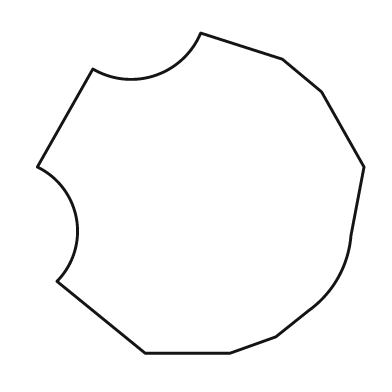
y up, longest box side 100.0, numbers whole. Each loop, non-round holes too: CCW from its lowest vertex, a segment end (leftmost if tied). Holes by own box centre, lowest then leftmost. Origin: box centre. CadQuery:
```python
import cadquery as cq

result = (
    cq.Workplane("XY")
    .moveTo(-17.0, -49.0)
    .lineTo(9.0, -49.0)
    .lineTo(23.0, -44.0)
    .lineTo(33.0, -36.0)
    .threePointArc((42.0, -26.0), (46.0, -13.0))
    .lineTo(50.0, 8.0)
    .lineTo(37.0, 31.0)
    .lineTo(25.0, 41.0)
    .lineTo(0.0, 49.0)
    .threePointArc((-14.0, 36.0), (-33.0, 38.0))
    .lineTo(-50.0, 8.0)
    .threePointArc((-38.0, -8.0), (-44.0, -27.0))
    .close()
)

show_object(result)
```